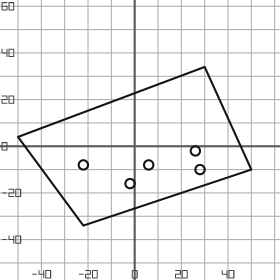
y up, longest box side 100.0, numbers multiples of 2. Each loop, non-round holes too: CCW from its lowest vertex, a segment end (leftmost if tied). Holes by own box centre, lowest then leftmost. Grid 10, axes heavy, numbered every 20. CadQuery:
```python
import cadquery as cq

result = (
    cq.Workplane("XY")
    .moveTo(-22.0, -34.0)
    .lineTo(50.0, -10.0)
    .lineTo(30.0, 34.0)
    .lineTo(-50.0, 4.0)
    .close()
    .moveTo(-2.0, -16.0)
    .circle(2.0)
    .moveTo(28.0, -10.0)
    .circle(2.0)
    .moveTo(-22.0, -8.0)
    .circle(2.0)
    .moveTo(6.0, -8.0)
    .circle(2.0)
    .moveTo(26.0, -2.0)
    .circle(2.0)
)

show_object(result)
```